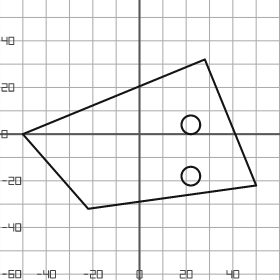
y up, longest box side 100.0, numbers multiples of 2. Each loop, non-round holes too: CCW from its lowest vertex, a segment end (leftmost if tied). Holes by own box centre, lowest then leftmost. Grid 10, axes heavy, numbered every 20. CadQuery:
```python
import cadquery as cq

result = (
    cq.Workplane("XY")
    .moveTo(-22.0, -32.0)
    .lineTo(50.0, -22.0)
    .lineTo(28.0, 32.0)
    .lineTo(-50.0, 0.0)
    .close()
    .moveTo(22.0, -18.0)
    .circle(4.0)
    .moveTo(22.0, 4.0)
    .circle(4.0)
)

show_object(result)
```